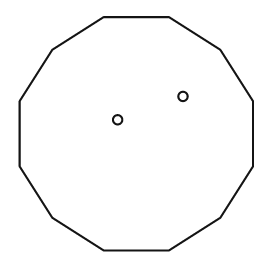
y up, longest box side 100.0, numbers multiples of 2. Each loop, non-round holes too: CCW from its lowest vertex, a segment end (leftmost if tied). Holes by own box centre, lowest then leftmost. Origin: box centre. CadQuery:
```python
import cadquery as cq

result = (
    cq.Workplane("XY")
    .moveTo(-14.0, -50.0)
    .lineTo(14.0, -50.0)
    .lineTo(36.0, -36.0)
    .lineTo(50.0, -14.0)
    .lineTo(50.0, 14.0)
    .lineTo(36.0, 36.0)
    .lineTo(14.0, 50.0)
    .lineTo(-14.0, 50.0)
    .lineTo(-36.0, 36.0)
    .lineTo(-50.0, 14.0)
    .lineTo(-50.0, -14.0)
    .lineTo(-36.0, -36.0)
    .close()
    .moveTo(-8.0, 6.0)
    .circle(2.0)
    .moveTo(20.0, 16.0)
    .circle(2.0)
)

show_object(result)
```